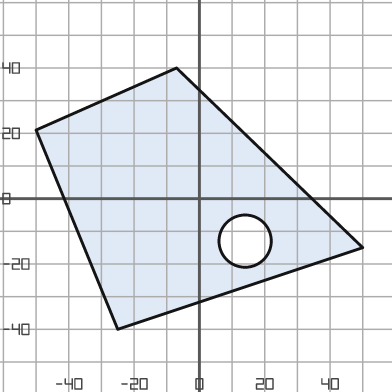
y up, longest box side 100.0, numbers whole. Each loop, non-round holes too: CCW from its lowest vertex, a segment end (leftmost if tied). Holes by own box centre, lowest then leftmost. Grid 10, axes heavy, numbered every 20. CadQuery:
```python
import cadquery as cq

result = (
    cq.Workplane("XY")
    .moveTo(-25.0, -40.0)
    .lineTo(50.0, -15.0)
    .lineTo(-7.0, 40.0)
    .lineTo(-50.0, 21.0)
    .close()
    .moveTo(14.0, -13.0)
    .circle(8.0)
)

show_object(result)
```